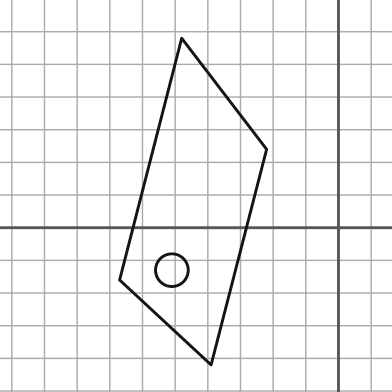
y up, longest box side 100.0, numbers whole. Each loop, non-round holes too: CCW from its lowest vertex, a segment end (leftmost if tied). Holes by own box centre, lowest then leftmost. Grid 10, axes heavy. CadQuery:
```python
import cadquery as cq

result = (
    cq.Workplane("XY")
    .moveTo(-39.0, -42.0)
    .lineTo(-22.0, 24.0)
    .lineTo(-48.0, 58.0)
    .lineTo(-67.0, -16.0)
    .close()
    .moveTo(-51.0, -13.0)
    .circle(5.0)
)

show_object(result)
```